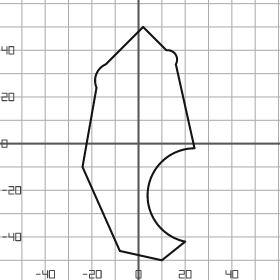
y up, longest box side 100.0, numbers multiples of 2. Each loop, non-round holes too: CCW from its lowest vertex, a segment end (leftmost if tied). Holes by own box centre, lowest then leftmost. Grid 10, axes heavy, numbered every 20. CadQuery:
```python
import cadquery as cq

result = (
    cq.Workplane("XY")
    .moveTo(10.0, -50.0)
    .lineTo(20.0, -42.0)
    .threePointArc((4.0, -20.0), (24.0, -2.0))
    .lineTo(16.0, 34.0)
    .threePointArc((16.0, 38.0), (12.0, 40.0))
    .lineTo(2.0, 50.0)
    .lineTo(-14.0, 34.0)
    .threePointArc((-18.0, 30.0), (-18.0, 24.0))
    .lineTo(-24.0, -10.0)
    .lineTo(-8.0, -46.0)
    .close()
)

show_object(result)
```